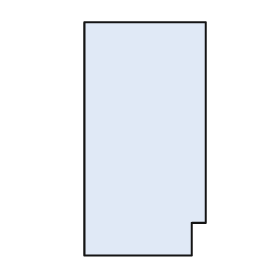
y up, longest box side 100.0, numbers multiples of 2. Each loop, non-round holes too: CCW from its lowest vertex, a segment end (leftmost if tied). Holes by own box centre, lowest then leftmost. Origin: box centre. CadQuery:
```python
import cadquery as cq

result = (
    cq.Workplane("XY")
    .moveTo(-26.0, -50.0)
    .lineTo(20.0, -50.0)
    .lineTo(20.0, -36.0)
    .lineTo(26.0, -36.0)
    .lineTo(26.0, 50.0)
    .lineTo(-26.0, 50.0)
    .close()
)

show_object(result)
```